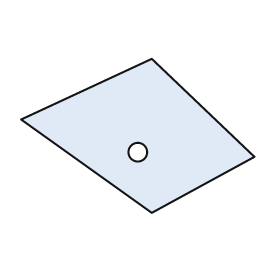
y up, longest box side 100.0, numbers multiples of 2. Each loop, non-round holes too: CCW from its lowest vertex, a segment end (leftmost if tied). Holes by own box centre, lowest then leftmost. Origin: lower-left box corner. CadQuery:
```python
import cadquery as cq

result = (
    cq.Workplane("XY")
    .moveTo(56.0, 0.0)
    .lineTo(100.0, 24.0)
    .lineTo(56.0, 66.0)
    .lineTo(0.0, 40.0)
    .close()
    .moveTo(50.0, 26.0)
    .circle(4.0)
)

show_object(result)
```